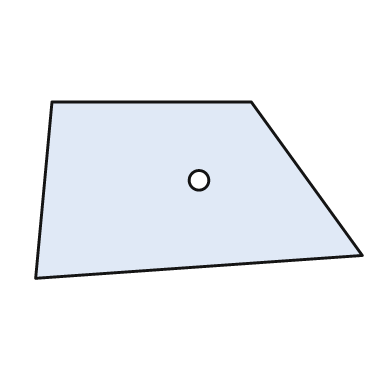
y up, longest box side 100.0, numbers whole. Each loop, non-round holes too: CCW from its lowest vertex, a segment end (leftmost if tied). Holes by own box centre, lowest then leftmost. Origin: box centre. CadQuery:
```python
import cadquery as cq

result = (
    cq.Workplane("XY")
    .moveTo(-50.0, -27.0)
    .lineTo(50.0, -20.0)
    .lineTo(16.0, 27.0)
    .lineTo(-45.0, 27.0)
    .close()
    .moveTo(0.0, 3.0)
    .circle(3.0)
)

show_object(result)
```